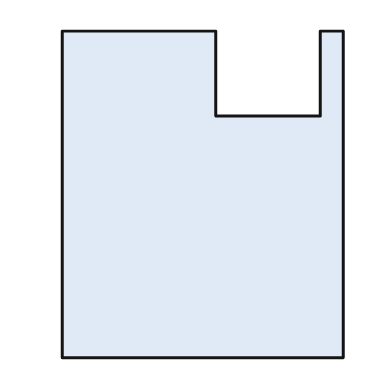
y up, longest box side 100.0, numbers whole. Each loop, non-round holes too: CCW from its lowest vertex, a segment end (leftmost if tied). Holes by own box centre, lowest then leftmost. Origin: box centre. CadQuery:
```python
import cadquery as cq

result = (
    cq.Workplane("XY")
    .moveTo(-43.0, -50.0)
    .lineTo(43.0, -50.0)
    .lineTo(43.0, 50.0)
    .lineTo(36.0, 50.0)
    .lineTo(36.0, 24.0)
    .lineTo(4.0, 24.0)
    .lineTo(4.0, 50.0)
    .lineTo(-43.0, 50.0)
    .close()
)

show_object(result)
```